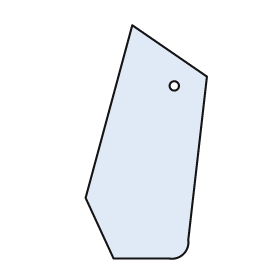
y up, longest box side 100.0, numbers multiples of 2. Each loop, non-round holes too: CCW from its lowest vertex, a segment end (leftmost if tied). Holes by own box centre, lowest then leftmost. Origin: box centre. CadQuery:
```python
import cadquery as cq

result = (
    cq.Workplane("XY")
    .moveTo(-14.0, -50.0)
    .lineTo(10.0, -50.0)
    .threePointArc((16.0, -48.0), (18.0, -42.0))
    .lineTo(26.0, 28.0)
    .lineTo(-6.0, 50.0)
    .lineTo(-26.0, -24.0)
    .close()
    .moveTo(12.0, 24.0)
    .circle(2.0)
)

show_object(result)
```